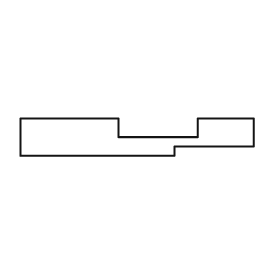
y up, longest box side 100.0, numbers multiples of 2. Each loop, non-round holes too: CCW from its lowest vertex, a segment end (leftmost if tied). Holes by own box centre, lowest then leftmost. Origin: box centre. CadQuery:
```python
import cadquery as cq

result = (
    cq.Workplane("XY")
    .moveTo(-50.0, -8.0)
    .lineTo(16.0, -8.0)
    .lineTo(16.0, -4.0)
    .lineTo(50.0, -4.0)
    .lineTo(50.0, 8.0)
    .lineTo(26.0, 8.0)
    .lineTo(26.0, 0.0)
    .lineTo(-8.0, 0.0)
    .lineTo(-8.0, 8.0)
    .lineTo(-50.0, 8.0)
    .close()
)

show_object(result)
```